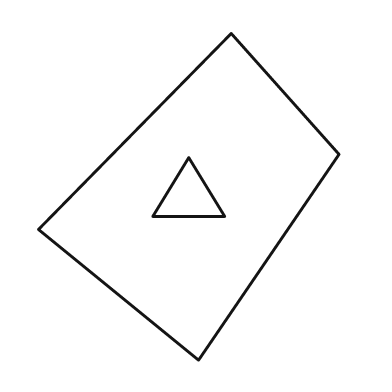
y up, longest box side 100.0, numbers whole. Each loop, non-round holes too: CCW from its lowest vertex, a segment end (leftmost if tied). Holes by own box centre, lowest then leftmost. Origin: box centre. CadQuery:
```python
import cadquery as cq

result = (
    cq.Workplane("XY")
    .moveTo(3.0, -50.0)
    .lineTo(46.0, 13.0)
    .lineTo(13.0, 50.0)
    .lineTo(-46.0, -10.0)
    .close()
    .moveTo(-11.0, -6.0)
    .lineTo(11.0, -6.0)
    .lineTo(0.0, 12.0)
    .close()
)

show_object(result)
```